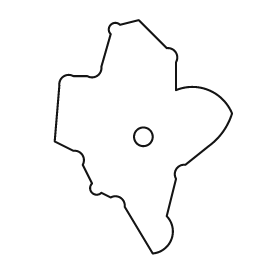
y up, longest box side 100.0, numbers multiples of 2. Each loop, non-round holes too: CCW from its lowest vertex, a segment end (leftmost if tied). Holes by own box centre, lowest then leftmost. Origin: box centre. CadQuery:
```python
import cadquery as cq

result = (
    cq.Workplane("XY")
    .moveTo(4.0, -50.0)
    .threePointArc((12.0, -44.0), (10.0, -34.0))
    .lineTo(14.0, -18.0)
    .threePointArc((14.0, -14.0), (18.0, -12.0))
    .lineTo(28.0, -4.0)
    .threePointArc((34.0, 2.0), (38.0, 10.0))
    .threePointArc((28.0, 20.0), (14.0, 20.0))
    .lineTo(14.0, 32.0)
    .threePointArc((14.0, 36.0), (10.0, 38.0))
    .lineTo(-2.0, 50.0)
    .lineTo(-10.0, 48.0)
    .threePointArc((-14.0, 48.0), (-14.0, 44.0))
    .lineTo(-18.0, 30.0)
    .threePointArc((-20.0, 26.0), (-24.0, 26.0))
    .lineTo(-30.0, 26.0)
    .threePointArc((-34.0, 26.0), (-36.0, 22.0))
    .lineTo(-38.0, -2.0)
    .lineTo(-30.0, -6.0)
    .threePointArc((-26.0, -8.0), (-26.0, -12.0))
    .lineTo(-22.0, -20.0)
    .threePointArc((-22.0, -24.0), (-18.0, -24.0))
    .lineTo(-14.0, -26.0)
    .threePointArc((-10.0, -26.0), (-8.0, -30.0))
    .close()
    .moveTo(0.0, 0.0)
    .circle(4.0)
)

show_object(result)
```